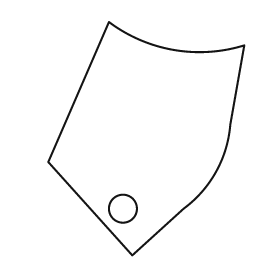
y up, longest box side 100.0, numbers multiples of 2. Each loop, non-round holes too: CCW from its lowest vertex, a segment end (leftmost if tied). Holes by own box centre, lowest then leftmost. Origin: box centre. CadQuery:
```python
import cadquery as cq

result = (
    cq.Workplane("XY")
    .moveTo(-6.0, -50.0)
    .lineTo(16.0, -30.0)
    .threePointArc((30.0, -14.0), (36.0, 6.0))
    .lineTo(42.0, 40.0)
    .threePointArc((12.0, 38.0), (-16.0, 50.0))
    .lineTo(-42.0, -10.0)
    .close()
    .moveTo(-10.0, -30.0)
    .circle(6.0)
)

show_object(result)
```